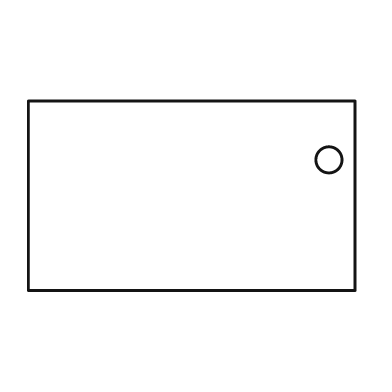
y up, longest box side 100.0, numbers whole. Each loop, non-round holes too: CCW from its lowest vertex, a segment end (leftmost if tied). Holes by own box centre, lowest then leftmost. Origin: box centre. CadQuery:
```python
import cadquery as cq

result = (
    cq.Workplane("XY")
    .moveTo(-50.0, -29.0)
    .lineTo(50.0, -29.0)
    .lineTo(50.0, 29.0)
    .lineTo(-50.0, 29.0)
    .close()
    .moveTo(42.0, 11.0)
    .circle(4.0)
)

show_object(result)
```